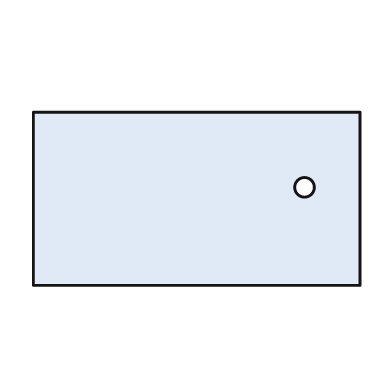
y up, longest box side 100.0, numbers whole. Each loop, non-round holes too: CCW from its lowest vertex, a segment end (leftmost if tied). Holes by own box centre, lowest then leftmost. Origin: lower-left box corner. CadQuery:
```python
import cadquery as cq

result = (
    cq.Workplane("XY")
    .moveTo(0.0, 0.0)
    .lineTo(100.0, 0.0)
    .lineTo(100.0, 53.0)
    .lineTo(0.0, 53.0)
    .close()
    .moveTo(83.0, 30.0)
    .circle(3.0)
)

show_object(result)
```